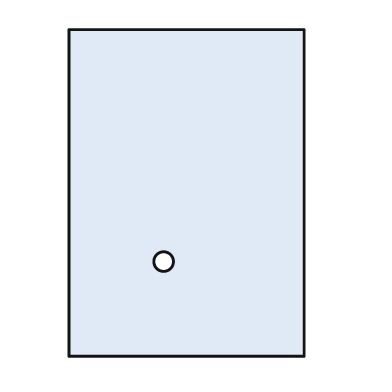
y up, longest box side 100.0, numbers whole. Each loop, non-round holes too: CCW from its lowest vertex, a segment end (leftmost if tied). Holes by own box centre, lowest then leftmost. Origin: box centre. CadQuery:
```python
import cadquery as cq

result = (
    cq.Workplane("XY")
    .moveTo(-36.0, -50.0)
    .lineTo(36.0, -50.0)
    .lineTo(36.0, 50.0)
    .lineTo(-36.0, 50.0)
    .close()
    .moveTo(-7.0, -21.0)
    .circle(3.0)
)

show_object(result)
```